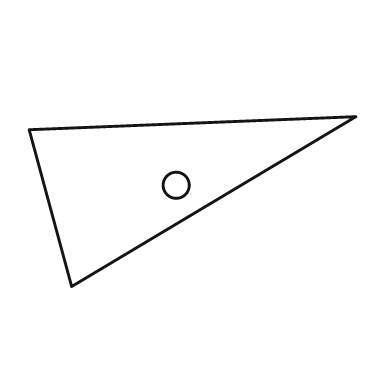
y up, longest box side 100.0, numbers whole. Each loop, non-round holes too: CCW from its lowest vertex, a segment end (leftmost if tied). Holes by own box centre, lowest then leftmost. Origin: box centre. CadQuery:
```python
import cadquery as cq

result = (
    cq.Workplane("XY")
    .moveTo(-37.0, -26.0)
    .lineTo(50.0, 26.0)
    .lineTo(-50.0, 22.0)
    .close()
    .moveTo(-5.0, 5.0)
    .circle(4.0)
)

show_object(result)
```